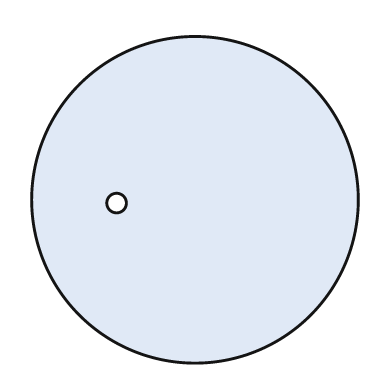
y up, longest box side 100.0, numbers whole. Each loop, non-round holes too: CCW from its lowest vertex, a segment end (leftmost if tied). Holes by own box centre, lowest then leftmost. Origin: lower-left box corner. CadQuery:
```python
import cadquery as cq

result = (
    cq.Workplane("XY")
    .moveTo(50.0, 50.0)
    .circle(50.0)
    .moveTo(26.0, 49.0)
    .circle(3.0)
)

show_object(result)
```